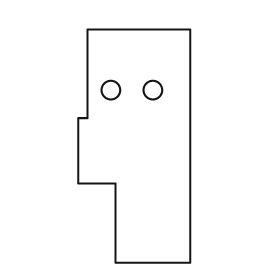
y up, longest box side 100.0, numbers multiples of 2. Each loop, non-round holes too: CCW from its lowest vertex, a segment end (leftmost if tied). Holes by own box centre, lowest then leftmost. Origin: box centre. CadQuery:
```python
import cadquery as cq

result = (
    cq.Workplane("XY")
    .moveTo(-8.0, -50.0)
    .lineTo(24.0, -50.0)
    .lineTo(24.0, 50.0)
    .lineTo(-20.0, 50.0)
    .lineTo(-20.0, 12.0)
    .lineTo(-24.0, 12.0)
    .lineTo(-24.0, -16.0)
    .lineTo(-8.0, -16.0)
    .close()
    .moveTo(-10.0, 24.0)
    .circle(4.0)
    .moveTo(8.0, 24.0)
    .circle(4.0)
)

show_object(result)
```